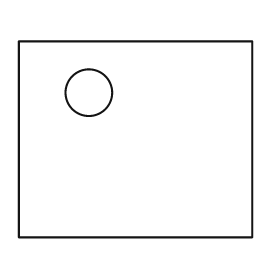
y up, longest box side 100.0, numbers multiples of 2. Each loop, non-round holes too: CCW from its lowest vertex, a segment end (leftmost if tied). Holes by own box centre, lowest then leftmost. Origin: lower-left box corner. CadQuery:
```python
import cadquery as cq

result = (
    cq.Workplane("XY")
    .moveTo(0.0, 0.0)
    .lineTo(100.0, 0.0)
    .lineTo(100.0, 84.0)
    .lineTo(0.0, 84.0)
    .close()
    .moveTo(30.0, 62.0)
    .circle(10.0)
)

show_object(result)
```